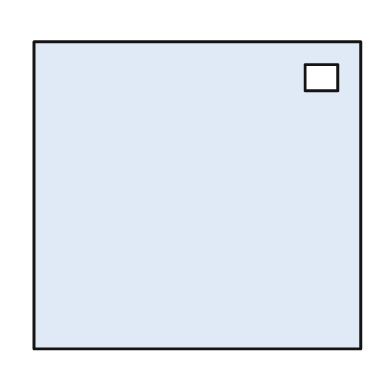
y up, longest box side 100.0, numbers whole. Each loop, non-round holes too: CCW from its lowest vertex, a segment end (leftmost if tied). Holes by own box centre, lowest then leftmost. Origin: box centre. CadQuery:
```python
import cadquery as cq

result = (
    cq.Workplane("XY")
    .moveTo(-50.0, -47.0)
    .lineTo(50.0, -47.0)
    .lineTo(50.0, 47.0)
    .lineTo(-50.0, 47.0)
    .close()
    .moveTo(33.0, 32.0)
    .lineTo(43.0, 32.0)
    .lineTo(43.0, 40.0)
    .lineTo(33.0, 40.0)
    .close()
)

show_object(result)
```